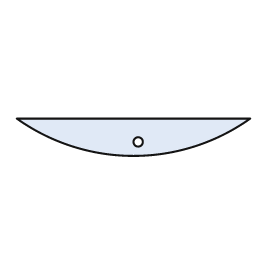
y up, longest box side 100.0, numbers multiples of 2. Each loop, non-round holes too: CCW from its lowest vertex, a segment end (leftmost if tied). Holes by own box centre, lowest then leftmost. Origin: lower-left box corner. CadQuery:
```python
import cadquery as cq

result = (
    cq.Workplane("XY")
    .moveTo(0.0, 16.0)
    .threePointArc((50.0, 0.0), (100.0, 16.0))
    .close()
    .moveTo(52.0, 6.0)
    .circle(2.0)
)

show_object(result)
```